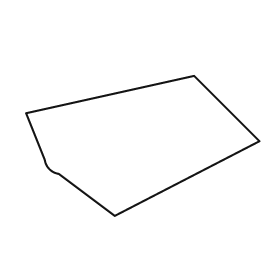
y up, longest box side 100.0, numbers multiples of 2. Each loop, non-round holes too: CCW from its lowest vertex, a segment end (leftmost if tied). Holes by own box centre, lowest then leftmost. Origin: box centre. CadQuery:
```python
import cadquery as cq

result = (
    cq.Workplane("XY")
    .moveTo(-12.0, -30.0)
    .lineTo(50.0, 2.0)
    .lineTo(22.0, 30.0)
    .lineTo(-50.0, 14.0)
    .lineTo(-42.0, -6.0)
    .threePointArc((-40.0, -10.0), (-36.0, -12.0))
    .close()
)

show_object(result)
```